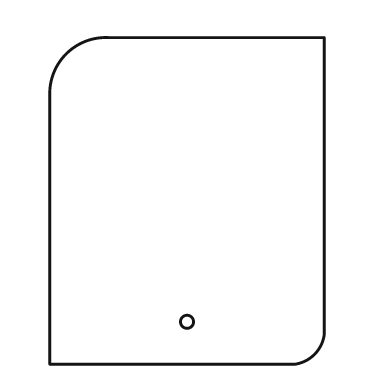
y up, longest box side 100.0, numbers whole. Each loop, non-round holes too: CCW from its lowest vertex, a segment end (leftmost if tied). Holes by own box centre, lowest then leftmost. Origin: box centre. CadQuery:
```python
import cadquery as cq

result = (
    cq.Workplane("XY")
    .moveTo(-42.0, -50.0)
    .lineTo(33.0, -50.0)
    .threePointArc((39.0, -47.0), (42.0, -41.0))
    .lineTo(42.0, 50.0)
    .lineTo(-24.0, 50.0)
    .threePointArc((-37.0, 45.0), (-42.0, 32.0))
    .close()
    .moveTo(0.0, -37.0)
    .circle(2.0)
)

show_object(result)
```